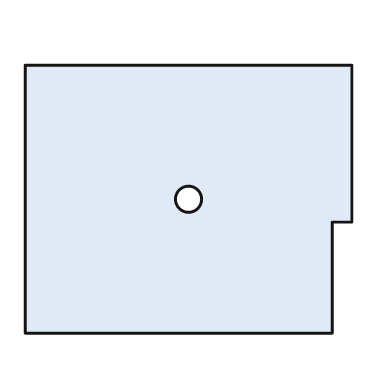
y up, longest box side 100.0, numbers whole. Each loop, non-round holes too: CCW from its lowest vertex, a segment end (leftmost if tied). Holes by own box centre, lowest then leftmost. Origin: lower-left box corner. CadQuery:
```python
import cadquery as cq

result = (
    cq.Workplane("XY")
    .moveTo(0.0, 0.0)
    .lineTo(94.0, 0.0)
    .lineTo(94.0, 34.0)
    .lineTo(100.0, 34.0)
    .lineTo(100.0, 82.0)
    .lineTo(0.0, 82.0)
    .close()
    .moveTo(50.0, 41.0)
    .circle(4.0)
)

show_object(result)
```